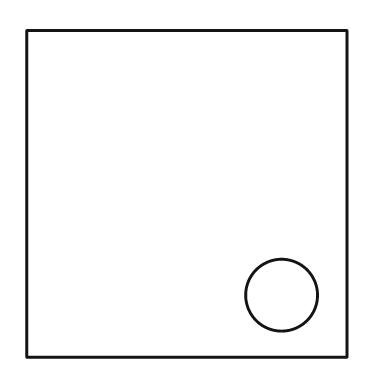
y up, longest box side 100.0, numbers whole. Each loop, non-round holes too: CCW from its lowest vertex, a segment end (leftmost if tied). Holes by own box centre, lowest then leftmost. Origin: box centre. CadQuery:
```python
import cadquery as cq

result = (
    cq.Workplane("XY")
    .moveTo(-49.0, -50.0)
    .lineTo(49.0, -50.0)
    .lineTo(49.0, 50.0)
    .lineTo(-49.0, 50.0)
    .close()
    .moveTo(29.0, -31.0)
    .circle(11.0)
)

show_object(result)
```